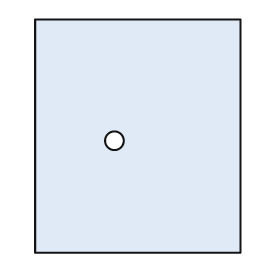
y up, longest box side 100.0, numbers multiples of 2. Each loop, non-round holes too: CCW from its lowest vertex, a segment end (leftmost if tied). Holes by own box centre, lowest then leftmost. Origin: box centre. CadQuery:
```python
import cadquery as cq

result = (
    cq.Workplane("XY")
    .moveTo(-44.0, -50.0)
    .lineTo(44.0, -50.0)
    .lineTo(44.0, 50.0)
    .lineTo(-44.0, 50.0)
    .close()
    .moveTo(-10.0, -2.0)
    .circle(4.0)
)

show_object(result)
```